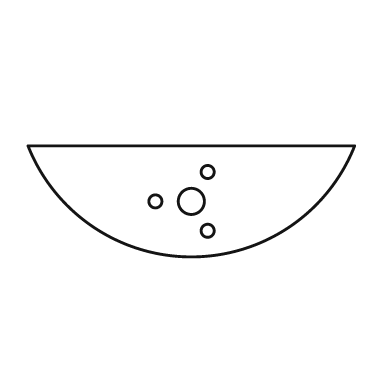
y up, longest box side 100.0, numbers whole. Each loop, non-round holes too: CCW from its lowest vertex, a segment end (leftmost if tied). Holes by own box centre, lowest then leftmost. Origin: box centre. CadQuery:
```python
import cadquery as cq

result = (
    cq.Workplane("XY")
    .moveTo(-50.0, 17.0)
    .threePointArc((0.0, -17.0), (50.0, 17.0))
    .close()
    .moveTo(5.0, -9.0)
    .circle(2.0)
    .moveTo(-11.0, 0.0)
    .circle(2.0)
    .moveTo(0.0, 0.0)
    .circle(4.0)
    .moveTo(5.0, 9.0)
    .circle(2.0)
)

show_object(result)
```